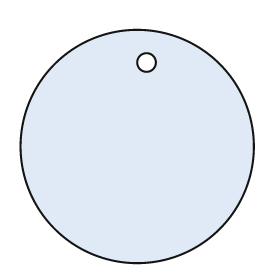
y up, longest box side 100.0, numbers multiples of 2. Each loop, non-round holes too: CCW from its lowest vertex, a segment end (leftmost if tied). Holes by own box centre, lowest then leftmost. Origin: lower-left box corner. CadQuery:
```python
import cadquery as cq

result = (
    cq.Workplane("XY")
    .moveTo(50.0, 50.0)
    .circle(50.0)
    .moveTo(54.0, 86.0)
    .circle(4.0)
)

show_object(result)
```